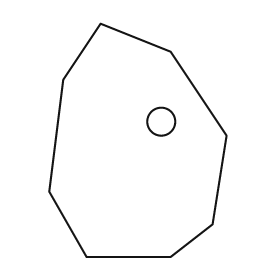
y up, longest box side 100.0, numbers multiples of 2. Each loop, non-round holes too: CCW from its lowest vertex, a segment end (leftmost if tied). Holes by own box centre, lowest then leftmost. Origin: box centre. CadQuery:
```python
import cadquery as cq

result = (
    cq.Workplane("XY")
    .moveTo(-22.0, -50.0)
    .lineTo(14.0, -50.0)
    .lineTo(32.0, -36.0)
    .lineTo(38.0, 2.0)
    .lineTo(14.0, 38.0)
    .lineTo(-16.0, 50.0)
    .lineTo(-32.0, 26.0)
    .lineTo(-38.0, -22.0)
    .close()
    .moveTo(10.0, 8.0)
    .circle(6.0)
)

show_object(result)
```